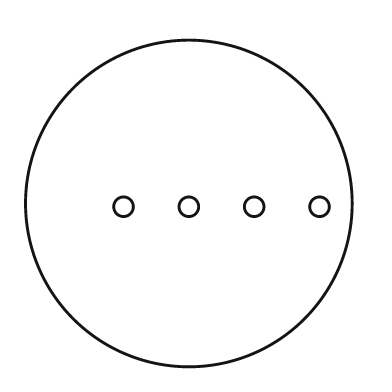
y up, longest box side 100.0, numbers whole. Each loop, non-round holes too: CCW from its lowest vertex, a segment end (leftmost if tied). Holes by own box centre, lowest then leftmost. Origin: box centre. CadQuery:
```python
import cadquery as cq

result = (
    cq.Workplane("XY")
    .moveTo(0.0, 0.0)
    .circle(50.0)
    .moveTo(-20.0, -1.0)
    .circle(3.0)
    .moveTo(0.0, -1.0)
    .circle(3.0)
    .moveTo(20.0, -1.0)
    .circle(3.0)
    .moveTo(40.0, -1.0)
    .circle(3.0)
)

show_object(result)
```